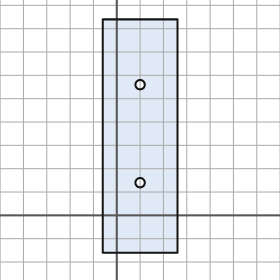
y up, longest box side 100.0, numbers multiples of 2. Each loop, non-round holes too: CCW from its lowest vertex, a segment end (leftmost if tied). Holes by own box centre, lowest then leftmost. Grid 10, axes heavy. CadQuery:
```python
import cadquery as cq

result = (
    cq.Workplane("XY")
    .moveTo(-6.0, -16.0)
    .lineTo(26.0, -16.0)
    .lineTo(26.0, 84.0)
    .lineTo(-6.0, 84.0)
    .close()
    .moveTo(10.0, 14.0)
    .circle(2.0)
    .moveTo(10.0, 56.0)
    .circle(2.0)
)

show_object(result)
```